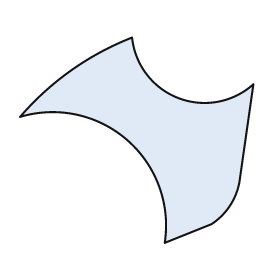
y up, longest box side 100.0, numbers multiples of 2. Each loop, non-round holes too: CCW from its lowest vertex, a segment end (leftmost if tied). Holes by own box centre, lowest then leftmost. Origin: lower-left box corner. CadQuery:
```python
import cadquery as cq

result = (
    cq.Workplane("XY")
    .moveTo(62.0, 0.0)
    .lineTo(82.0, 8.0)
    .threePointArc((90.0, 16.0), (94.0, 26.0))
    .lineTo(100.0, 68.0)
    .threePointArc((68.0, 62.0), (48.0, 88.0))
    .threePointArc((22.0, 74.0), (0.0, 54.0))
    .threePointArc((46.0, 44.0), (62.0, 0.0))
    .close()
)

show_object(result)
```